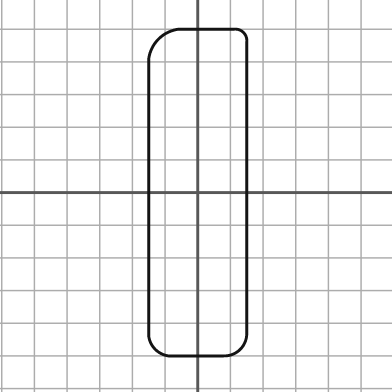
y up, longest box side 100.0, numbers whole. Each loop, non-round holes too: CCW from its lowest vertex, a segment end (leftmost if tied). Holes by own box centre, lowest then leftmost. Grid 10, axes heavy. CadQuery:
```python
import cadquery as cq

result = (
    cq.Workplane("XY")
    .moveTo(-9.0, -50.0)
    .lineTo(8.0, -50.0)
    .threePointArc((13.0, -48.0), (15.0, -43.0))
    .lineTo(15.0, 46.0)
    .threePointArc((14.0, 49.0), (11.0, 50.0))
    .lineTo(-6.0, 50.0)
    .threePointArc((-12.0, 47.0), (-15.0, 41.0))
    .lineTo(-15.0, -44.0)
    .threePointArc((-13.0, -48.0), (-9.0, -50.0))
    .close()
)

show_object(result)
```